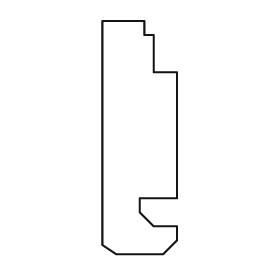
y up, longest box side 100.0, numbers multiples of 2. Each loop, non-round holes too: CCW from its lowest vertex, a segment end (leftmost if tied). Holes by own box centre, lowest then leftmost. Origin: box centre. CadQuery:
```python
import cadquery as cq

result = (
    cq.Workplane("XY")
    .moveTo(-10.0, -50.0)
    .lineTo(10.0, -50.0)
    .lineTo(16.0, -44.0)
    .lineTo(16.0, -38.0)
    .lineTo(6.0, -38.0)
    .lineTo(0.0, -32.0)
    .lineTo(0.0, -26.0)
    .lineTo(16.0, -26.0)
    .lineTo(16.0, 28.0)
    .lineTo(6.0, 28.0)
    .lineTo(6.0, 44.0)
    .lineTo(2.0, 44.0)
    .lineTo(2.0, 50.0)
    .lineTo(-16.0, 50.0)
    .lineTo(-16.0, -46.0)
    .close()
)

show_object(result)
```